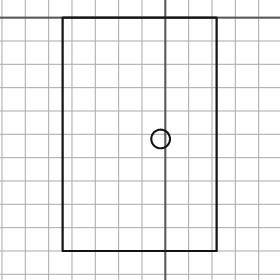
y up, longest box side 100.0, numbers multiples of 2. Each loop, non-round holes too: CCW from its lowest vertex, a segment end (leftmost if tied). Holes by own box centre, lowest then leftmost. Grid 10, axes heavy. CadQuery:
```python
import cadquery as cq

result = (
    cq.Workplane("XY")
    .moveTo(-44.0, -100.0)
    .lineTo(22.0, -100.0)
    .lineTo(22.0, 0.0)
    .lineTo(-44.0, 0.0)
    .close()
    .moveTo(-2.0, -52.0)
    .circle(4.0)
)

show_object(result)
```